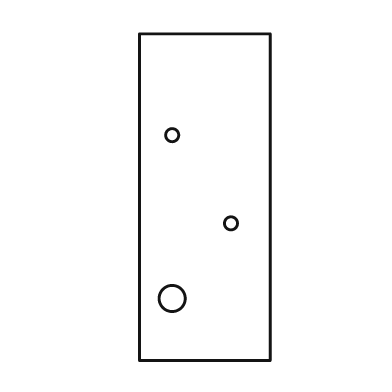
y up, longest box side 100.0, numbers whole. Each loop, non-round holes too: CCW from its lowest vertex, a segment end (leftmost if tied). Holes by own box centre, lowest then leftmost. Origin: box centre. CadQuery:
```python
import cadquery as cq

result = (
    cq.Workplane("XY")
    .moveTo(-20.0, -50.0)
    .lineTo(20.0, -50.0)
    .lineTo(20.0, 50.0)
    .lineTo(-20.0, 50.0)
    .close()
    .moveTo(-10.0, -31.0)
    .circle(4.0)
    .moveTo(8.0, -8.0)
    .circle(2.0)
    .moveTo(-10.0, 19.0)
    .circle(2.0)
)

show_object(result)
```